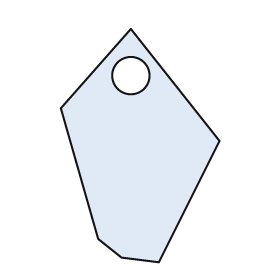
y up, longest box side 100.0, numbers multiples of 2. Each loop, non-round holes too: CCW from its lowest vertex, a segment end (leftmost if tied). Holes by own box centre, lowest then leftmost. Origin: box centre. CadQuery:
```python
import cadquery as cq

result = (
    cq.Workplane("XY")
    .moveTo(8.0, -50.0)
    .lineTo(34.0, 2.0)
    .lineTo(-4.0, 50.0)
    .lineTo(-34.0, 16.0)
    .lineTo(-18.0, -40.0)
    .lineTo(-8.0, -48.0)
    .close()
    .moveTo(-4.0, 30.0)
    .circle(8.0)
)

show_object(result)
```